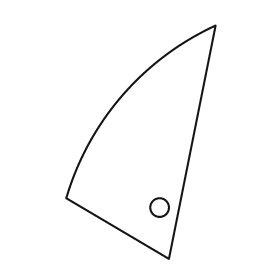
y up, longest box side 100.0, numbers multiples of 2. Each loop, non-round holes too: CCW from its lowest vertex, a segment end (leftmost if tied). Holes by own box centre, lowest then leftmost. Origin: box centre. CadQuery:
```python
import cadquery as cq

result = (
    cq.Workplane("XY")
    .moveTo(12.0, -50.0)
    .lineTo(32.0, 50.0)
    .threePointArc((-8.0, 20.0), (-32.0, -24.0))
    .close()
    .moveTo(8.0, -28.0)
    .circle(4.0)
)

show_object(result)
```